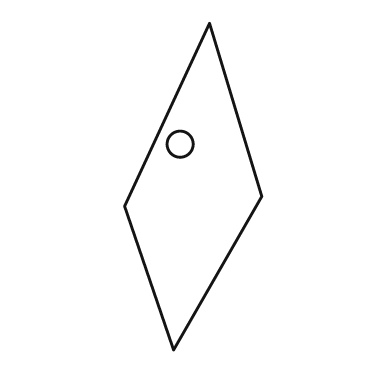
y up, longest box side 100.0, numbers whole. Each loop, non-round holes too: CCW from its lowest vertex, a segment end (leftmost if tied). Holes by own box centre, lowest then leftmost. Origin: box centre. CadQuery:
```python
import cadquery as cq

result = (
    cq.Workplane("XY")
    .moveTo(-6.0, -50.0)
    .lineTo(21.0, -3.0)
    .lineTo(5.0, 50.0)
    .lineTo(-21.0, -6.0)
    .close()
    .moveTo(-4.0, 13.0)
    .circle(4.0)
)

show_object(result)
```